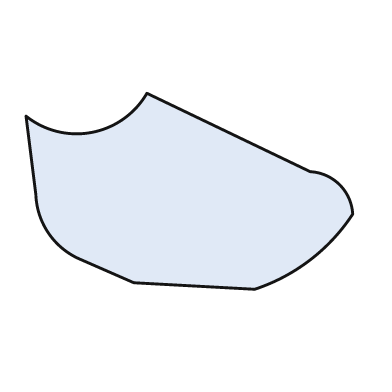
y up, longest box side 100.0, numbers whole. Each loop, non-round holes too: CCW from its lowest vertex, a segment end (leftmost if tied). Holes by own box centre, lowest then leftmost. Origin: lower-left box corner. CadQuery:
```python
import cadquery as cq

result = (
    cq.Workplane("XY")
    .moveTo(70.0, 0.0)
    .threePointArc((87.0, 9.0), (100.0, 23.0))
    .threePointArc((96.0, 32.0), (87.0, 36.0))
    .lineTo(37.0, 60.0)
    .threePointArc((20.0, 48.0), (0.0, 53.0))
    .lineTo(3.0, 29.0)
    .threePointArc((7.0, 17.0), (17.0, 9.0))
    .lineTo(33.0, 2.0)
    .close()
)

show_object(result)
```